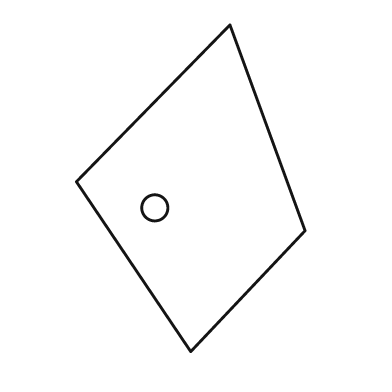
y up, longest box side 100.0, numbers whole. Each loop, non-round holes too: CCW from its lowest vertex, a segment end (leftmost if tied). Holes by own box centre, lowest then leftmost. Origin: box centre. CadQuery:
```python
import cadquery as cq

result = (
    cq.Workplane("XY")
    .moveTo(0.0, -50.0)
    .lineTo(35.0, -13.0)
    .lineTo(12.0, 50.0)
    .lineTo(-35.0, 2.0)
    .close()
    .moveTo(-11.0, -6.0)
    .circle(4.0)
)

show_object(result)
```